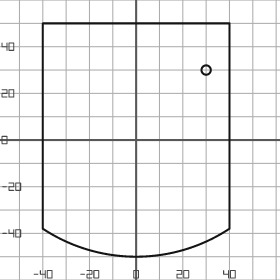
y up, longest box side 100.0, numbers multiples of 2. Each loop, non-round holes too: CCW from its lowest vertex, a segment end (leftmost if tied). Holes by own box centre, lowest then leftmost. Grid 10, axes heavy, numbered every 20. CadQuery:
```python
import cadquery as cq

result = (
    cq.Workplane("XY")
    .moveTo(-40.0, -38.0)
    .threePointArc((0.0, -50.0), (40.0, -38.0))
    .lineTo(40.0, 50.0)
    .lineTo(-40.0, 50.0)
    .close()
    .moveTo(30.0, 30.0)
    .circle(2.0)
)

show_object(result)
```